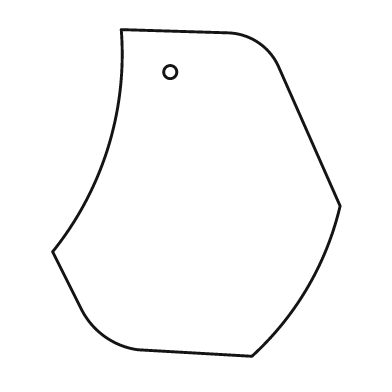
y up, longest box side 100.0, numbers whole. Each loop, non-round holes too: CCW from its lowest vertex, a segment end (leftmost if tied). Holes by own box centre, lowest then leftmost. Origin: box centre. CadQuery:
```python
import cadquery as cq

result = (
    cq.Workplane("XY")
    .moveTo(17.0, -50.0)
    .threePointArc((34.0, -29.0), (44.0, -4.0))
    .lineTo(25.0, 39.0)
    .threePointArc((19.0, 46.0), (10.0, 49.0))
    .lineTo(-23.0, 50.0)
    .threePointArc((-27.0, 14.0), (-44.0, -18.0))
    .lineTo(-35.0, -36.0)
    .threePointArc((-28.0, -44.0), (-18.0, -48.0))
    .close()
    .moveTo(-8.0, 37.0)
    .circle(2.0)
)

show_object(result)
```